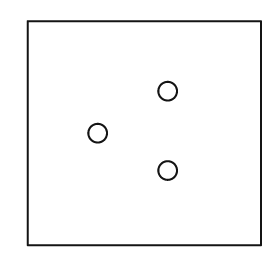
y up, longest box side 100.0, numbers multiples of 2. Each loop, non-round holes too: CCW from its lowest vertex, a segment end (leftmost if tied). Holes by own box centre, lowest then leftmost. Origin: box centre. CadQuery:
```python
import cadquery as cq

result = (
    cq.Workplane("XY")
    .moveTo(-50.0, -48.0)
    .lineTo(50.0, -48.0)
    .lineTo(50.0, 48.0)
    .lineTo(-50.0, 48.0)
    .close()
    .moveTo(10.0, -16.0)
    .circle(4.0)
    .moveTo(-20.0, 0.0)
    .circle(4.0)
    .moveTo(10.0, 18.0)
    .circle(4.0)
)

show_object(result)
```